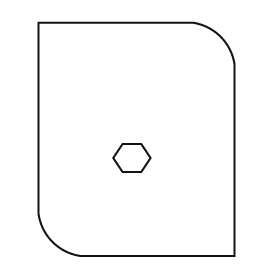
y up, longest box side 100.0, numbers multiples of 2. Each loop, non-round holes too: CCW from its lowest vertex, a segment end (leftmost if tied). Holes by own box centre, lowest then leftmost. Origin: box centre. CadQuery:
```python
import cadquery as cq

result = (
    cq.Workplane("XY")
    .moveTo(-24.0, -50.0)
    .lineTo(42.0, -50.0)
    .lineTo(42.0, 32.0)
    .threePointArc((36.0, 44.0), (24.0, 50.0))
    .lineTo(-42.0, 50.0)
    .lineTo(-42.0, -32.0)
    .threePointArc((-36.0, -44.0), (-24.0, -50.0))
    .close()
    .moveTo(-6.0, -14.0)
    .lineTo(2.0, -14.0)
    .lineTo(6.0, -8.0)
    .lineTo(2.0, -2.0)
    .lineTo(-6.0, -2.0)
    .lineTo(-10.0, -8.0)
    .close()
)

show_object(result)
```